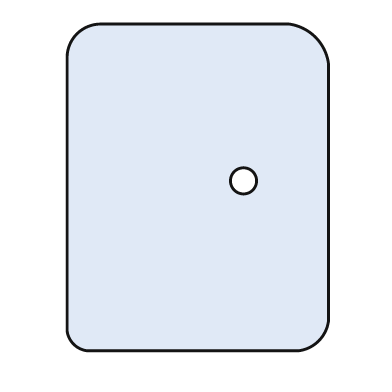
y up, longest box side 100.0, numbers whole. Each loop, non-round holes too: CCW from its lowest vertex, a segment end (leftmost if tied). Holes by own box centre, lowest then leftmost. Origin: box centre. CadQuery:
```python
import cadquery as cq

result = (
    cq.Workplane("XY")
    .moveTo(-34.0, -50.0)
    .lineTo(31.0, -50.0)
    .threePointArc((37.0, -47.0), (40.0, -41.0))
    .lineTo(40.0, 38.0)
    .threePointArc((36.0, 46.0), (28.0, 50.0))
    .lineTo(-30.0, 50.0)
    .threePointArc((-37.0, 47.0), (-40.0, 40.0))
    .lineTo(-40.0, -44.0)
    .threePointArc((-38.0, -48.0), (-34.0, -50.0))
    .close()
    .moveTo(14.0, 2.0)
    .circle(4.0)
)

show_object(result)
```